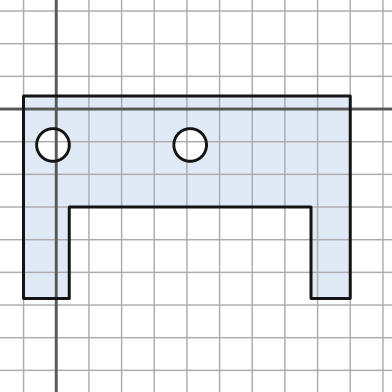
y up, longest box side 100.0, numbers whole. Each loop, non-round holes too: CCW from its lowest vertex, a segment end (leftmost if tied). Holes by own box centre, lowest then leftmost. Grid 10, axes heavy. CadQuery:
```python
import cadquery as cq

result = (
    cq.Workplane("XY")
    .moveTo(-10.0, -58.0)
    .lineTo(4.0, -58.0)
    .lineTo(4.0, -30.0)
    .lineTo(78.0, -30.0)
    .lineTo(78.0, -58.0)
    .lineTo(90.0, -58.0)
    .lineTo(90.0, 4.0)
    .lineTo(-10.0, 4.0)
    .close()
    .moveTo(-1.0, -11.0)
    .circle(5.0)
    .moveTo(41.0, -11.0)
    .circle(5.0)
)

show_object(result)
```